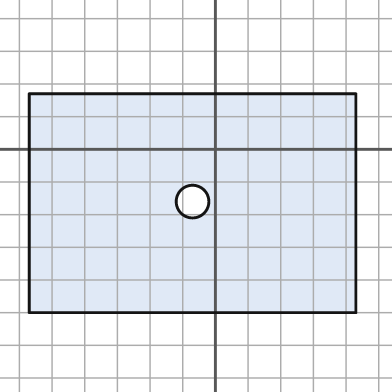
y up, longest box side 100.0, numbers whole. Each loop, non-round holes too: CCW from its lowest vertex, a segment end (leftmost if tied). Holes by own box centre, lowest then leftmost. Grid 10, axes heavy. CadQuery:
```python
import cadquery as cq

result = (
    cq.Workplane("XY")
    .moveTo(-57.0, -50.0)
    .lineTo(43.0, -50.0)
    .lineTo(43.0, 17.0)
    .lineTo(-57.0, 17.0)
    .close()
    .moveTo(-7.0, -16.0)
    .circle(5.0)
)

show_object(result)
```